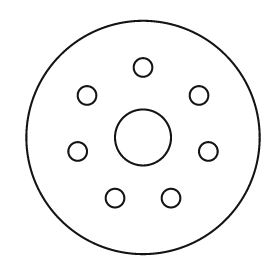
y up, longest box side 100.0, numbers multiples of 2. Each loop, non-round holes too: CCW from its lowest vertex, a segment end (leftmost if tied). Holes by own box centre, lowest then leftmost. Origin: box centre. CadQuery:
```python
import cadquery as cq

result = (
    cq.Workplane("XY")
    .moveTo(0.0, 0.0)
    .circle(50.0)
    .moveTo(-12.0, -26.0)
    .circle(4.0)
    .moveTo(12.0, -26.0)
    .circle(4.0)
    .moveTo(-28.0, -6.0)
    .circle(4.0)
    .moveTo(28.0, -6.0)
    .circle(4.0)
    .moveTo(0.0, 0.0)
    .circle(12.0)
    .moveTo(-24.0, 18.0)
    .circle(4.0)
    .moveTo(24.0, 18.0)
    .circle(4.0)
    .moveTo(0.0, 30.0)
    .circle(4.0)
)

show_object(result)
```